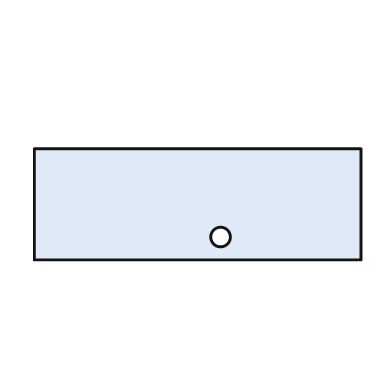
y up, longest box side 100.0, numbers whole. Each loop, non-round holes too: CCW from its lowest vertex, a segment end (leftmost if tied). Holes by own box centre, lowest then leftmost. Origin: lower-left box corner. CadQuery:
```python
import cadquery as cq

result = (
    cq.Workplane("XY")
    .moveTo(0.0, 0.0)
    .lineTo(100.0, 0.0)
    .lineTo(100.0, 34.0)
    .lineTo(0.0, 34.0)
    .close()
    .moveTo(57.0, 7.0)
    .circle(3.0)
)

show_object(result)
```